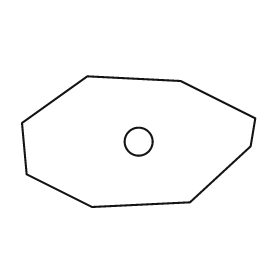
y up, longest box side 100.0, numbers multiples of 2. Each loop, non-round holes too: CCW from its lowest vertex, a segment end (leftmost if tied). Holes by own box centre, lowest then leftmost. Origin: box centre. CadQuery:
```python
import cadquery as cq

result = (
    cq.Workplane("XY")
    .moveTo(-20.0, -28.0)
    .lineTo(22.0, -26.0)
    .lineTo(48.0, -2.0)
    .lineTo(50.0, 10.0)
    .lineTo(18.0, 26.0)
    .lineTo(-22.0, 28.0)
    .lineTo(-50.0, 8.0)
    .lineTo(-48.0, -14.0)
    .close()
    .moveTo(0.0, 0.0)
    .circle(6.0)
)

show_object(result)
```